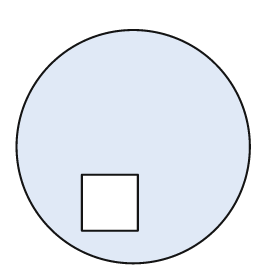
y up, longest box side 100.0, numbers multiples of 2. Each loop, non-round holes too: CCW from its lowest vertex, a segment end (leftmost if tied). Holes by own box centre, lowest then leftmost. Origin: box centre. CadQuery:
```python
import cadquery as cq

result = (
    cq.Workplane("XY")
    .moveTo(0.0, 0.0)
    .circle(50.0)
    .moveTo(-22.0, -36.0)
    .lineTo(2.0, -36.0)
    .lineTo(2.0, -12.0)
    .lineTo(-22.0, -12.0)
    .close()
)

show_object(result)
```